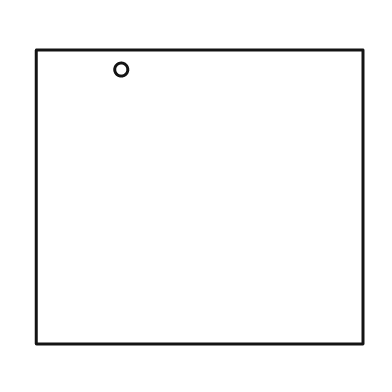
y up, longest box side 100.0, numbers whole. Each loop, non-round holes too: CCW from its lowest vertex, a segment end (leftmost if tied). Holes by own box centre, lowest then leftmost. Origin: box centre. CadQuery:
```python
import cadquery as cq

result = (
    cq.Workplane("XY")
    .moveTo(-50.0, -45.0)
    .lineTo(50.0, -45.0)
    .lineTo(50.0, 45.0)
    .lineTo(-50.0, 45.0)
    .close()
    .moveTo(-24.0, 39.0)
    .circle(2.0)
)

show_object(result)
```